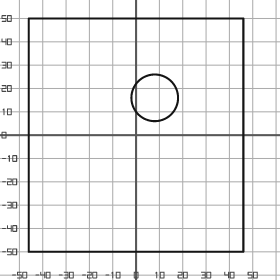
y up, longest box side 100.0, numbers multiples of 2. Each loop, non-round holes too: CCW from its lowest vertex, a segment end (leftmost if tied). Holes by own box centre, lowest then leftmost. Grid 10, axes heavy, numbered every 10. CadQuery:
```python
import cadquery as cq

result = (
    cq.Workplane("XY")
    .moveTo(-46.0, -50.0)
    .lineTo(46.0, -50.0)
    .lineTo(46.0, 50.0)
    .lineTo(-46.0, 50.0)
    .close()
    .moveTo(8.0, 16.0)
    .circle(10.0)
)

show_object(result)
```